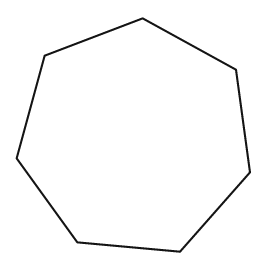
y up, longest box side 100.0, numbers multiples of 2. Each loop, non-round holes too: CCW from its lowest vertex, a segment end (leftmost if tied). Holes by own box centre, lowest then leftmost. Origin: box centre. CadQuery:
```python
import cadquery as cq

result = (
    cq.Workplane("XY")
    .moveTo(20.0, -50.0)
    .lineTo(50.0, -16.0)
    .lineTo(44.0, 28.0)
    .lineTo(4.0, 50.0)
    .lineTo(-38.0, 34.0)
    .lineTo(-50.0, -10.0)
    .lineTo(-24.0, -46.0)
    .close()
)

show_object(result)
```